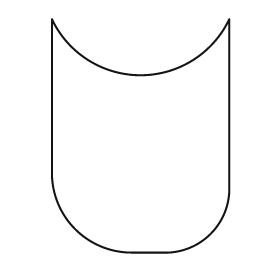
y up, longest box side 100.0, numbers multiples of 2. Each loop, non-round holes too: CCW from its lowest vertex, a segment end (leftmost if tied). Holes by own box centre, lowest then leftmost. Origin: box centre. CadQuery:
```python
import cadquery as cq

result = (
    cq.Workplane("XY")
    .moveTo(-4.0, -50.0)
    .lineTo(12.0, -50.0)
    .threePointArc((30.0, -42.0), (38.0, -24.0))
    .lineTo(38.0, 50.0)
    .threePointArc((0.0, 26.0), (-38.0, 50.0))
    .lineTo(-38.0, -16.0)
    .threePointArc((-28.0, -40.0), (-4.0, -50.0))
    .close()
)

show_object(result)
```